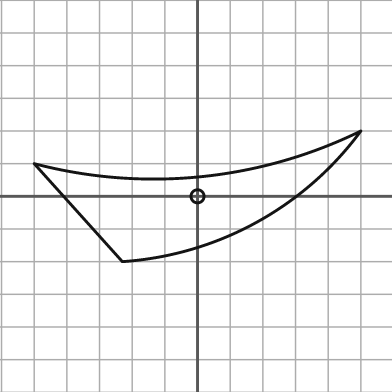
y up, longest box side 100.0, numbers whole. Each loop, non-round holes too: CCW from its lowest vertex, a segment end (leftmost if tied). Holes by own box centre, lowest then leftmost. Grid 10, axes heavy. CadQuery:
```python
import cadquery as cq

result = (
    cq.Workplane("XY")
    .moveTo(-23.0, -20.0)
    .threePointArc((18.0, -8.0), (50.0, 20.0))
    .threePointArc((1.0, 6.0), (-50.0, 10.0))
    .close()
    .moveTo(0.0, 0.0)
    .circle(2.0)
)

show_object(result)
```